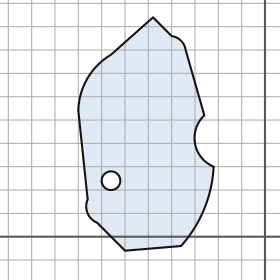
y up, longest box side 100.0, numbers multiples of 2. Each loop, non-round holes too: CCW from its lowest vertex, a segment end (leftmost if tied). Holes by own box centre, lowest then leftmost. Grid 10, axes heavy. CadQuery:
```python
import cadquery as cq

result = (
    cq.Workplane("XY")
    .moveTo(-60.0, -6.0)
    .lineTo(-36.0, -4.0)
    .threePointArc((-26.0, 12.0), (-22.0, 30.0))
    .threePointArc((-30.0, 40.0), (-26.0, 52.0))
    .lineTo(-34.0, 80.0)
    .threePointArc((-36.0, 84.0), (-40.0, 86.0))
    .lineTo(-48.0, 94.0)
    .lineTo(-66.0, 78.0)
    .threePointArc((-76.0, 68.0), (-80.0, 54.0))
    .lineTo(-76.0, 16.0)
    .threePointArc((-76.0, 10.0), (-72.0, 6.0))
    .close()
    .moveTo(-66.0, 24.0)
    .circle(4.0)
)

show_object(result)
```